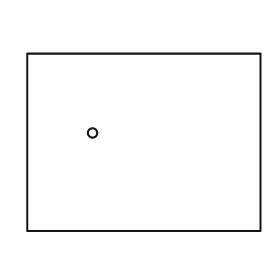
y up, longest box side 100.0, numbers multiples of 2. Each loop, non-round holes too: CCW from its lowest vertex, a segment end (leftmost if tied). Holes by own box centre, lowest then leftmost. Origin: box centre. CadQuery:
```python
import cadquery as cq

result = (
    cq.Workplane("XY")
    .moveTo(-50.0, -38.0)
    .lineTo(50.0, -38.0)
    .lineTo(50.0, 38.0)
    .lineTo(-50.0, 38.0)
    .close()
    .moveTo(-22.0, 4.0)
    .circle(2.0)
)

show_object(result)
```